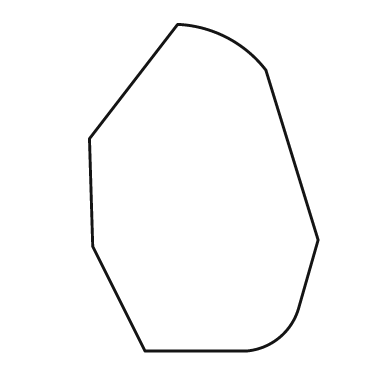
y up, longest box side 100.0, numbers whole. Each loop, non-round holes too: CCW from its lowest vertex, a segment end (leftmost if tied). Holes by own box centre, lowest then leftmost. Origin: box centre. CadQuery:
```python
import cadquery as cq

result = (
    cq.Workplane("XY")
    .moveTo(-18.0, -50.0)
    .lineTo(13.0, -50.0)
    .threePointArc((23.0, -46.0), (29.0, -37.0))
    .lineTo(35.0, -16.0)
    .lineTo(19.0, 36.0)
    .threePointArc((7.0, 46.0), (-8.0, 50.0))
    .lineTo(-35.0, 15.0)
    .lineTo(-34.0, -18.0)
    .close()
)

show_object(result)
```